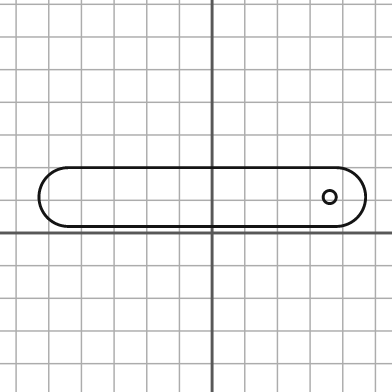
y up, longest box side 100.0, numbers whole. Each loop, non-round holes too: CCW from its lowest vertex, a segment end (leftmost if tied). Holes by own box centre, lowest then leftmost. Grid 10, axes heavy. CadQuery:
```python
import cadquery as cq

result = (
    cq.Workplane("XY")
    .moveTo(-44.0, 2.0)
    .lineTo(38.0, 2.0)
    .threePointArc((47.0, 11.0), (38.0, 20.0))
    .lineTo(-44.0, 20.0)
    .threePointArc((-53.0, 11.0), (-44.0, 2.0))
    .close()
    .moveTo(36.0, 11.0)
    .circle(2.0)
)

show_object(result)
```